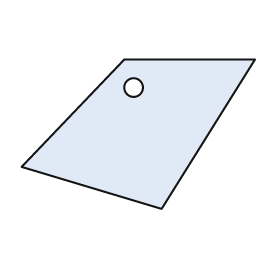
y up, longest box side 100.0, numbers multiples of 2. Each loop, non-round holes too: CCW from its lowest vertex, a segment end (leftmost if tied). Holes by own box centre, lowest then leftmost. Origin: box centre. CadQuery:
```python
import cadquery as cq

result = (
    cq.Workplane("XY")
    .moveTo(10.0, -32.0)
    .lineTo(50.0, 32.0)
    .lineTo(-6.0, 32.0)
    .lineTo(-50.0, -14.0)
    .close()
    .moveTo(-2.0, 20.0)
    .circle(4.0)
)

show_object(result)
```